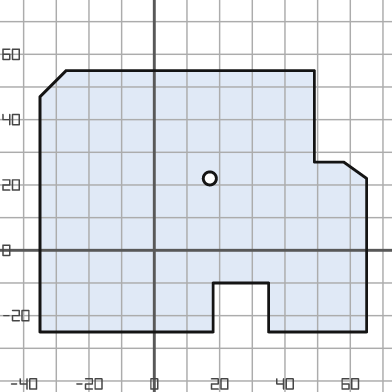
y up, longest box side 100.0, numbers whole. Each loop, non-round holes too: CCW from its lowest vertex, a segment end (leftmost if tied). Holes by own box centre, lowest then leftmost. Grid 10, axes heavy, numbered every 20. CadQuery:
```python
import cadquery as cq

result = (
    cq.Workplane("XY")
    .moveTo(-35.0, -25.0)
    .lineTo(18.0, -25.0)
    .lineTo(18.0, -10.0)
    .lineTo(35.0, -10.0)
    .lineTo(35.0, -25.0)
    .lineTo(65.0, -25.0)
    .lineTo(65.0, 22.0)
    .lineTo(58.0, 27.0)
    .lineTo(49.0, 27.0)
    .lineTo(49.0, 55.0)
    .lineTo(-27.0, 55.0)
    .lineTo(-35.0, 47.0)
    .close()
    .moveTo(17.0, 22.0)
    .circle(2.0)
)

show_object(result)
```